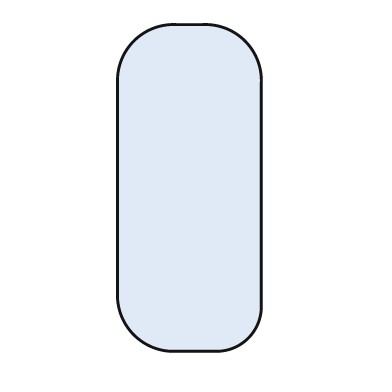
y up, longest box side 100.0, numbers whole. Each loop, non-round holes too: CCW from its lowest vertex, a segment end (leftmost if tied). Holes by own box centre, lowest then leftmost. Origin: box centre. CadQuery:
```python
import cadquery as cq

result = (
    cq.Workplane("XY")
    .moveTo(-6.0, -50.0)
    .lineTo(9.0, -50.0)
    .threePointArc((18.0, -46.0), (22.0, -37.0))
    .lineTo(22.0, 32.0)
    .threePointArc((17.0, 45.0), (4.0, 50.0))
    .lineTo(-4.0, 50.0)
    .threePointArc((-17.0, 45.0), (-22.0, 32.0))
    .lineTo(-22.0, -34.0)
    .threePointArc((-17.0, -45.0), (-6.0, -50.0))
    .close()
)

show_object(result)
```